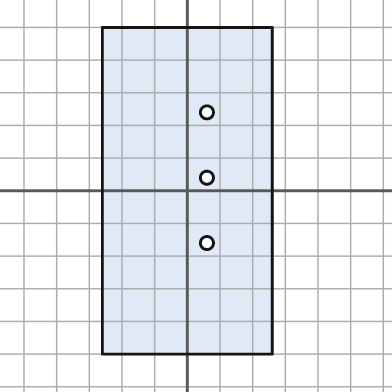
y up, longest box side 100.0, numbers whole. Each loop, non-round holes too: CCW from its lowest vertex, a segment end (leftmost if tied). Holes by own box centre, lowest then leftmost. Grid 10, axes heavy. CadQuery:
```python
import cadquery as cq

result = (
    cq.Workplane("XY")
    .moveTo(-26.0, -50.0)
    .lineTo(26.0, -50.0)
    .lineTo(26.0, 50.0)
    .lineTo(-26.0, 50.0)
    .close()
    .moveTo(6.0, -16.0)
    .circle(2.0)
    .moveTo(6.0, 4.0)
    .circle(2.0)
    .moveTo(6.0, 24.0)
    .circle(2.0)
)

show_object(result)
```